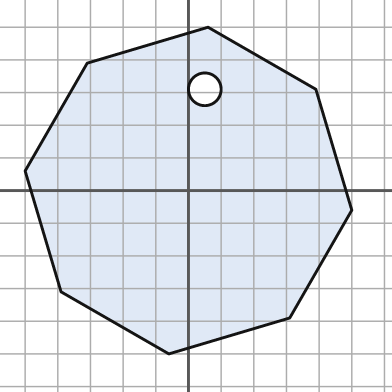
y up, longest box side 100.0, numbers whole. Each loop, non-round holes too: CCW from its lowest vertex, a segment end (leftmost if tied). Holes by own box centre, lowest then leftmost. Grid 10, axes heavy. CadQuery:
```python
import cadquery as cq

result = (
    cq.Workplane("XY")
    .moveTo(-6.0, -50.0)
    .lineTo(31.0, -39.0)
    .lineTo(50.0, -6.0)
    .lineTo(39.0, 31.0)
    .lineTo(6.0, 50.0)
    .lineTo(-31.0, 39.0)
    .lineTo(-50.0, 6.0)
    .lineTo(-39.0, -31.0)
    .close()
    .moveTo(5.0, 31.0)
    .circle(5.0)
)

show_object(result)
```